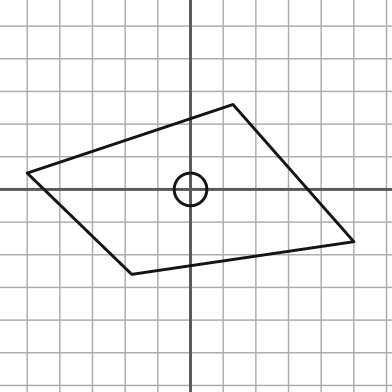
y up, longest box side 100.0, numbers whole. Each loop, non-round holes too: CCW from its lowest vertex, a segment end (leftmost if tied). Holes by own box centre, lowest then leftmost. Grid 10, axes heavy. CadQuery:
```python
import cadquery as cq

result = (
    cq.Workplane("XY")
    .moveTo(-18.0, -26.0)
    .lineTo(50.0, -16.0)
    .lineTo(13.0, 26.0)
    .lineTo(-50.0, 5.0)
    .close()
    .moveTo(0.0, 0.0)
    .circle(5.0)
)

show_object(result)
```